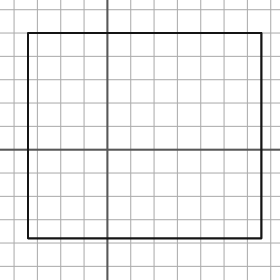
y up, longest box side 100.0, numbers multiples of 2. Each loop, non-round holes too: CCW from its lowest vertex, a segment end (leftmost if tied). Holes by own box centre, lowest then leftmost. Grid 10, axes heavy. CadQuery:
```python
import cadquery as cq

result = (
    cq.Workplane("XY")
    .moveTo(-34.0, -38.0)
    .lineTo(66.0, -38.0)
    .lineTo(66.0, 50.0)
    .lineTo(-34.0, 50.0)
    .close()
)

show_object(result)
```